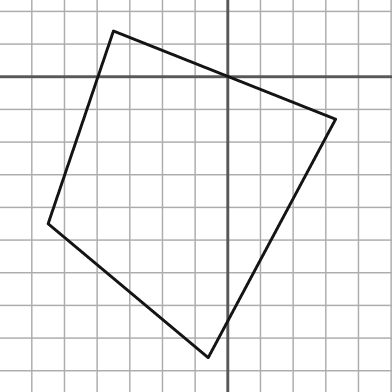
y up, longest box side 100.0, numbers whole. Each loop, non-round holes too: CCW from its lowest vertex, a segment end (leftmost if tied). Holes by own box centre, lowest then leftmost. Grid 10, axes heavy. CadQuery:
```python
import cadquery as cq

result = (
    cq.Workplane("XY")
    .moveTo(-6.0, -86.0)
    .lineTo(33.0, -13.0)
    .lineTo(-35.0, 14.0)
    .lineTo(-55.0, -45.0)
    .close()
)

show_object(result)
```